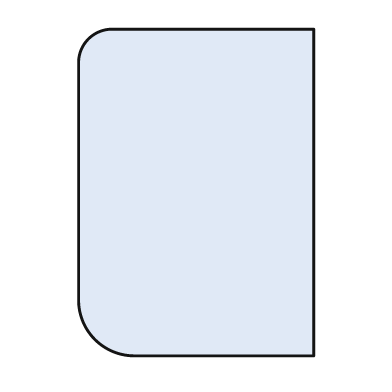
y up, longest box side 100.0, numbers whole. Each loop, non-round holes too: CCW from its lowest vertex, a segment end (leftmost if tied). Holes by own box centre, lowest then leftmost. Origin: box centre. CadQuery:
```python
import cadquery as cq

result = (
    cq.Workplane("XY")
    .moveTo(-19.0, -50.0)
    .lineTo(36.0, -50.0)
    .lineTo(36.0, 50.0)
    .lineTo(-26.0, 50.0)
    .threePointArc((-33.0, 47.0), (-36.0, 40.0))
    .lineTo(-36.0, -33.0)
    .threePointArc((-31.0, -45.0), (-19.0, -50.0))
    .close()
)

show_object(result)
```